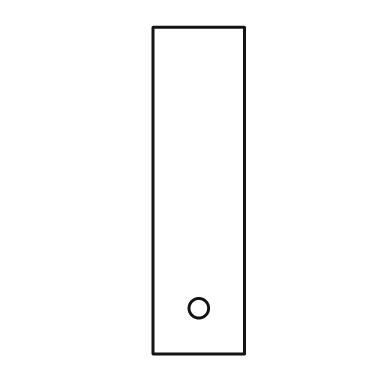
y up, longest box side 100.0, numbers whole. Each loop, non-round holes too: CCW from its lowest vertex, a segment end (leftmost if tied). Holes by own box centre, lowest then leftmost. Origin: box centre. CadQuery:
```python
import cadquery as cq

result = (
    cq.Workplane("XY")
    .moveTo(-14.0, -50.0)
    .lineTo(14.0, -50.0)
    .lineTo(14.0, 50.0)
    .lineTo(-14.0, 50.0)
    .close()
    .moveTo(0.0, -36.0)
    .circle(3.0)
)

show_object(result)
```